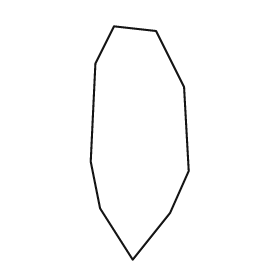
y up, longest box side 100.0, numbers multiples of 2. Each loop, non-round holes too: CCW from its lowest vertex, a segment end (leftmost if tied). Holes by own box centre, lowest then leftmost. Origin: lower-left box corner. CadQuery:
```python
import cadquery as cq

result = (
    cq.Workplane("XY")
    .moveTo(18.0, 0.0)
    .lineTo(34.0, 20.0)
    .lineTo(42.0, 38.0)
    .lineTo(40.0, 74.0)
    .lineTo(28.0, 98.0)
    .lineTo(10.0, 100.0)
    .lineTo(2.0, 84.0)
    .lineTo(0.0, 42.0)
    .lineTo(4.0, 22.0)
    .close()
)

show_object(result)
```